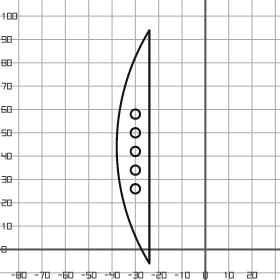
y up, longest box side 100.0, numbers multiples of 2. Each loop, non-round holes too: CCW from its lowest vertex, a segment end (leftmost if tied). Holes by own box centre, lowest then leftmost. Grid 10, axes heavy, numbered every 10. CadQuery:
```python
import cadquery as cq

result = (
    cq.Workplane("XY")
    .moveTo(-24.0, -6.0)
    .lineTo(-24.0, 94.0)
    .threePointArc((-38.0, 44.0), (-24.0, -6.0))
    .close()
    .moveTo(-30.0, 26.0)
    .circle(2.0)
    .moveTo(-30.0, 34.0)
    .circle(2.0)
    .moveTo(-30.0, 42.0)
    .circle(2.0)
    .moveTo(-30.0, 50.0)
    .circle(2.0)
    .moveTo(-30.0, 58.0)
    .circle(2.0)
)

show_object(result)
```